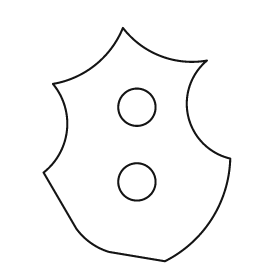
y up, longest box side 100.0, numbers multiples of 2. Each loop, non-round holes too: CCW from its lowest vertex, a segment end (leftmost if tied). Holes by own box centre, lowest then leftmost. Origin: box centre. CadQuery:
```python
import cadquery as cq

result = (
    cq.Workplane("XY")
    .moveTo(12.0, -50.0)
    .threePointArc((32.0, -32.0), (40.0, -6.0))
    .threePointArc((22.0, 12.0), (30.0, 36.0))
    .threePointArc((10.0, 38.0), (-6.0, 50.0))
    .threePointArc((-18.0, 34.0), (-36.0, 26.0))
    .threePointArc((-30.0, 6.0), (-40.0, -12.0))
    .lineTo(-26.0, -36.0)
    .threePointArc((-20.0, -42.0), (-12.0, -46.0))
    .close()
    .moveTo(0.0, -16.0)
    .circle(8.0)
    .moveTo(0.0, 16.0)
    .circle(8.0)
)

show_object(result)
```